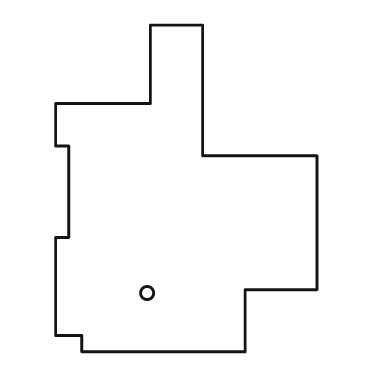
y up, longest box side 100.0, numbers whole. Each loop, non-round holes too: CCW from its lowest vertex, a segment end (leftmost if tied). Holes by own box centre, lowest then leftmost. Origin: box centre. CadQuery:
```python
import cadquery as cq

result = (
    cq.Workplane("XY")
    .moveTo(-32.0, -50.0)
    .lineTo(18.0, -50.0)
    .lineTo(18.0, -31.0)
    .lineTo(40.0, -31.0)
    .lineTo(40.0, 10.0)
    .lineTo(5.0, 10.0)
    .lineTo(5.0, 50.0)
    .lineTo(-11.0, 50.0)
    .lineTo(-11.0, 26.0)
    .lineTo(-40.0, 26.0)
    .lineTo(-40.0, 13.0)
    .lineTo(-36.0, 13.0)
    .lineTo(-36.0, -15.0)
    .lineTo(-40.0, -15.0)
    .lineTo(-40.0, -45.0)
    .lineTo(-32.0, -45.0)
    .close()
    .moveTo(-12.0, -32.0)
    .circle(2.0)
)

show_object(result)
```